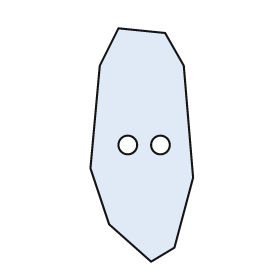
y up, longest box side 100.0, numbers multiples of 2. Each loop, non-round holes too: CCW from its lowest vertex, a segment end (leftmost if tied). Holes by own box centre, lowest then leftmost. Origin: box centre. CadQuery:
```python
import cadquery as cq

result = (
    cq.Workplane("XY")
    .moveTo(4.0, -50.0)
    .lineTo(14.0, -44.0)
    .lineTo(22.0, -14.0)
    .lineTo(18.0, 34.0)
    .lineTo(10.0, 48.0)
    .lineTo(-10.0, 50.0)
    .lineTo(-18.0, 34.0)
    .lineTo(-22.0, -10.0)
    .lineTo(-14.0, -34.0)
    .close()
    .moveTo(-6.0, 0.0)
    .circle(4.0)
    .moveTo(8.0, 0.0)
    .circle(4.0)
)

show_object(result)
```